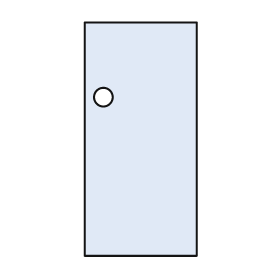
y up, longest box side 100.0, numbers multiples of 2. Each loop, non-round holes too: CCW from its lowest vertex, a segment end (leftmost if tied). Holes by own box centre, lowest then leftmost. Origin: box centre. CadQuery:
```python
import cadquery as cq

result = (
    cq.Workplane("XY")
    .moveTo(-24.0, -50.0)
    .lineTo(24.0, -50.0)
    .lineTo(24.0, 50.0)
    .lineTo(-24.0, 50.0)
    .close()
    .moveTo(-16.0, 18.0)
    .circle(4.0)
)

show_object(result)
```